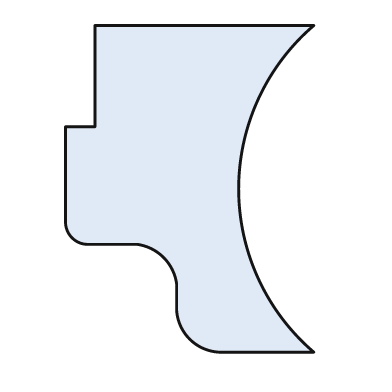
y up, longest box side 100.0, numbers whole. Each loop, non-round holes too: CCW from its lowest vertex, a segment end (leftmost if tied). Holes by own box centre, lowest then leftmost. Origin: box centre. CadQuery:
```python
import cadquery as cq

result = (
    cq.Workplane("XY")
    .moveTo(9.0, -50.0)
    .lineTo(38.0, -50.0)
    .threePointArc((15.0, 0.0), (38.0, 50.0))
    .lineTo(-29.0, 50.0)
    .lineTo(-29.0, 19.0)
    .lineTo(-38.0, 19.0)
    .lineTo(-38.0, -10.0)
    .threePointArc((-36.0, -15.0), (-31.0, -17.0))
    .lineTo(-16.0, -17.0)
    .threePointArc((-8.0, -21.0), (-4.0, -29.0))
    .lineTo(-4.0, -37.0)
    .threePointArc((0.0, -46.0), (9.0, -50.0))
    .close()
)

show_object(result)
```